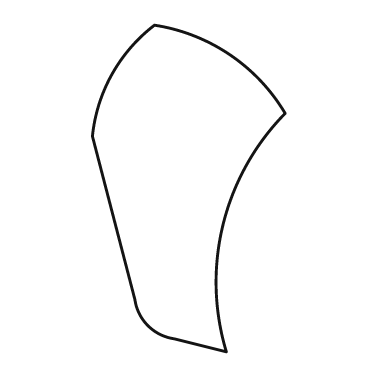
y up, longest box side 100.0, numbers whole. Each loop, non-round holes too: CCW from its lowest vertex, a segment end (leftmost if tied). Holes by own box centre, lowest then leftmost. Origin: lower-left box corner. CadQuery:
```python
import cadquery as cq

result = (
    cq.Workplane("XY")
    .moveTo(41.0, 0.0)
    .threePointArc((40.0, 39.0), (59.0, 73.0))
    .threePointArc((42.0, 91.0), (19.0, 100.0))
    .threePointArc((6.0, 85.0), (0.0, 66.0))
    .lineTo(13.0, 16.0)
    .threePointArc((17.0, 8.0), (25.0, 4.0))
    .close()
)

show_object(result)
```